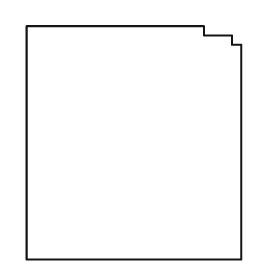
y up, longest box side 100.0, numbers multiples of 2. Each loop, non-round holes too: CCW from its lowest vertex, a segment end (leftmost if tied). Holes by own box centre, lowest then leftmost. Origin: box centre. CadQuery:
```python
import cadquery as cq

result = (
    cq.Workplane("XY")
    .moveTo(-46.0, -50.0)
    .lineTo(46.0, -50.0)
    .lineTo(46.0, 42.0)
    .lineTo(42.0, 42.0)
    .lineTo(42.0, 46.0)
    .lineTo(30.0, 46.0)
    .lineTo(30.0, 50.0)
    .lineTo(-46.0, 50.0)
    .close()
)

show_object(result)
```